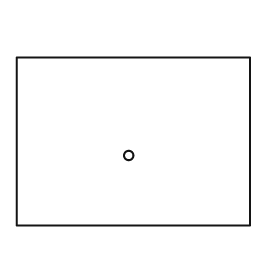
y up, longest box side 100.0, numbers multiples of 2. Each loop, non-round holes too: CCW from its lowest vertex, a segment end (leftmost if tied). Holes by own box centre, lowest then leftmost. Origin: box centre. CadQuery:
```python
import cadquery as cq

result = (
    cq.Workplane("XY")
    .moveTo(-50.0, -36.0)
    .lineTo(50.0, -36.0)
    .lineTo(50.0, 36.0)
    .lineTo(-50.0, 36.0)
    .close()
    .moveTo(-2.0, -6.0)
    .circle(2.0)
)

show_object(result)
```